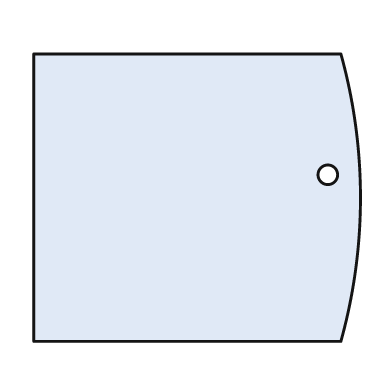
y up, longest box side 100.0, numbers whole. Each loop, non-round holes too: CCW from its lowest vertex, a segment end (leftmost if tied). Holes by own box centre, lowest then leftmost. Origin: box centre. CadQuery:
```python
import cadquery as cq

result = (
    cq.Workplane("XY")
    .moveTo(-50.0, -44.0)
    .lineTo(44.0, -44.0)
    .threePointArc((50.0, 0.0), (44.0, 44.0))
    .lineTo(-50.0, 44.0)
    .close()
    .moveTo(40.0, 7.0)
    .circle(3.0)
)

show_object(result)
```